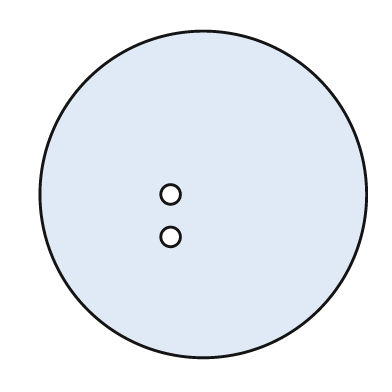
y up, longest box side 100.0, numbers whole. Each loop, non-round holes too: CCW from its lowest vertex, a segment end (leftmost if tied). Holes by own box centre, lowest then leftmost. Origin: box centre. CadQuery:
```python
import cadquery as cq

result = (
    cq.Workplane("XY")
    .moveTo(0.0, 0.0)
    .circle(50.0)
    .moveTo(-10.0, -13.0)
    .circle(3.0)
    .moveTo(-10.0, 0.0)
    .circle(3.0)
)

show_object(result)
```